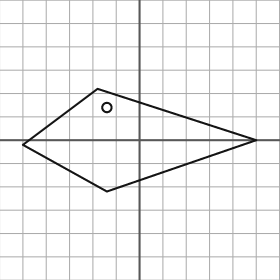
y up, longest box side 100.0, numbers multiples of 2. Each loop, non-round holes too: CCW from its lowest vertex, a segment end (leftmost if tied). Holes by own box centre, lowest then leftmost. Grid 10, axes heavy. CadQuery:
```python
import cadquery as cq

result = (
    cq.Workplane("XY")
    .moveTo(-14.0, -22.0)
    .lineTo(50.0, 0.0)
    .lineTo(-18.0, 22.0)
    .lineTo(-50.0, -2.0)
    .close()
    .moveTo(-14.0, 14.0)
    .circle(2.0)
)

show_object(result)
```